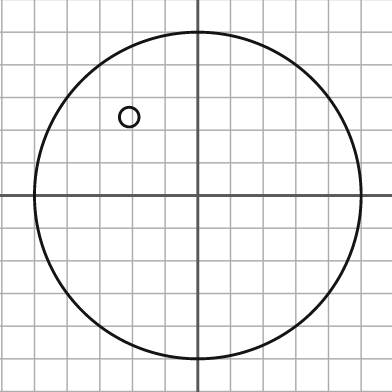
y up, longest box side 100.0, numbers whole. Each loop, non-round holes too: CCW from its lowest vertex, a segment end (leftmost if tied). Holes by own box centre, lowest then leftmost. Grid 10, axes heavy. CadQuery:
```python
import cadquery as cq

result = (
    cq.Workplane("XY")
    .moveTo(0.0, 0.0)
    .circle(50.0)
    .moveTo(-21.0, 24.0)
    .circle(3.0)
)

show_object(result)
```